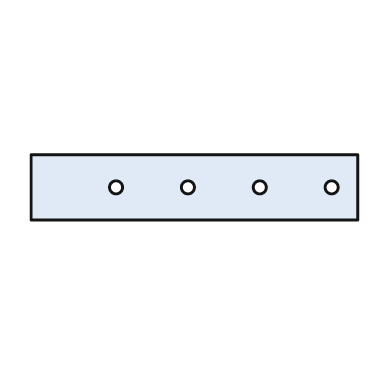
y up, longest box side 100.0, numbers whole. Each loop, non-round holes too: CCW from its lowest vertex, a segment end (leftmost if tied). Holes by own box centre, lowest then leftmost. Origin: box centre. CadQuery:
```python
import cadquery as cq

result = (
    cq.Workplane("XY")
    .moveTo(-50.0, -10.0)
    .lineTo(50.0, -10.0)
    .lineTo(50.0, 10.0)
    .lineTo(-50.0, 10.0)
    .close()
    .moveTo(-24.0, 0.0)
    .circle(2.0)
    .moveTo(-2.0, 0.0)
    .circle(2.0)
    .moveTo(20.0, 0.0)
    .circle(2.0)
    .moveTo(42.0, 0.0)
    .circle(2.0)
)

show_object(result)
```